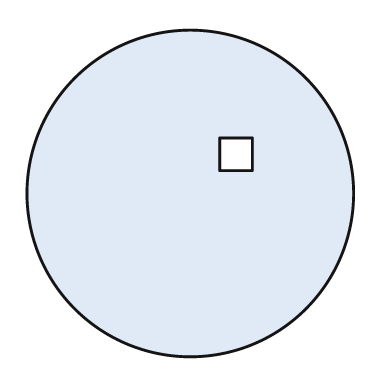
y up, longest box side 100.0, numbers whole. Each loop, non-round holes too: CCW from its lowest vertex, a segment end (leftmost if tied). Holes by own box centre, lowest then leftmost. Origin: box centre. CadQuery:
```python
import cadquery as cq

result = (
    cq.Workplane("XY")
    .moveTo(0.0, 0.0)
    .circle(50.0)
    .moveTo(9.0, 7.0)
    .lineTo(19.0, 7.0)
    .lineTo(19.0, 17.0)
    .lineTo(9.0, 17.0)
    .close()
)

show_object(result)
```